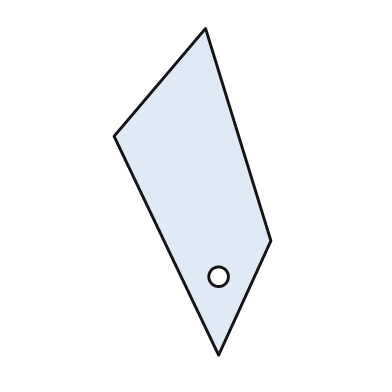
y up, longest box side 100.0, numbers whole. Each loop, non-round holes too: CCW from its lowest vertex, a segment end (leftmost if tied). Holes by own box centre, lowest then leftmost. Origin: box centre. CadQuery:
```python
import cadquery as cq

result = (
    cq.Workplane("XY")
    .moveTo(8.0, -50.0)
    .lineTo(24.0, -15.0)
    .lineTo(4.0, 50.0)
    .lineTo(-24.0, 17.0)
    .close()
    .moveTo(8.0, -26.0)
    .circle(3.0)
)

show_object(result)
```